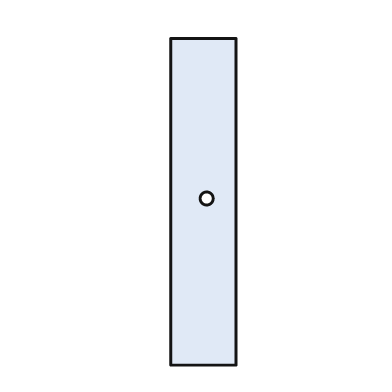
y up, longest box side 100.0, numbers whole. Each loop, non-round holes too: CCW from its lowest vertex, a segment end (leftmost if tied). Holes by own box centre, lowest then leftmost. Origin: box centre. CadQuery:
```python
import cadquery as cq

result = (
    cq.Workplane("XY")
    .moveTo(-10.0, -50.0)
    .lineTo(10.0, -50.0)
    .lineTo(10.0, 50.0)
    .lineTo(-10.0, 50.0)
    .close()
    .moveTo(1.0, 1.0)
    .circle(2.0)
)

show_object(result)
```